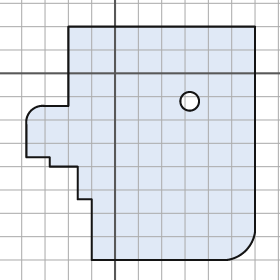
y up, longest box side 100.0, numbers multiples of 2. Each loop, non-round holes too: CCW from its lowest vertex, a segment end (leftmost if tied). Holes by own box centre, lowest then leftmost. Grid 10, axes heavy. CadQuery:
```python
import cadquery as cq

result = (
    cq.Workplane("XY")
    .moveTo(-10.0, -80.0)
    .lineTo(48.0, -80.0)
    .threePointArc((56.0, -76.0), (60.0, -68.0))
    .lineTo(60.0, 20.0)
    .lineTo(-20.0, 20.0)
    .lineTo(-20.0, -14.0)
    .lineTo(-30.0, -14.0)
    .threePointArc((-36.0, -16.0), (-38.0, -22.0))
    .lineTo(-38.0, -36.0)
    .lineTo(-28.0, -36.0)
    .lineTo(-28.0, -40.0)
    .lineTo(-16.0, -40.0)
    .lineTo(-16.0, -54.0)
    .lineTo(-10.0, -54.0)
    .close()
    .moveTo(32.0, -12.0)
    .circle(4.0)
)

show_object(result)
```